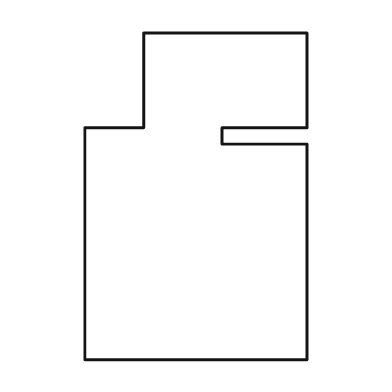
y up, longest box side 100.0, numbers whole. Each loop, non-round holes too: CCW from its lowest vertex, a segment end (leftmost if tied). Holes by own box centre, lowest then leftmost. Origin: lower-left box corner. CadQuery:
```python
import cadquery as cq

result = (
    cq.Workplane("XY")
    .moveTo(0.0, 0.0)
    .lineTo(68.0, 0.0)
    .lineTo(68.0, 66.0)
    .lineTo(42.0, 66.0)
    .lineTo(42.0, 71.0)
    .lineTo(68.0, 71.0)
    .lineTo(68.0, 100.0)
    .lineTo(18.0, 100.0)
    .lineTo(18.0, 71.0)
    .lineTo(0.0, 71.0)
    .close()
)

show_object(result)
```